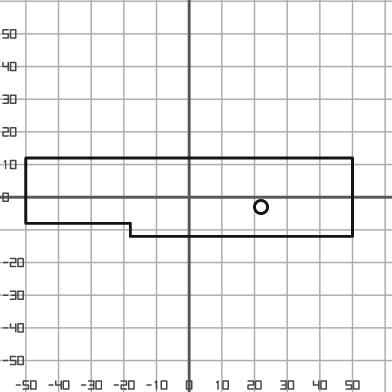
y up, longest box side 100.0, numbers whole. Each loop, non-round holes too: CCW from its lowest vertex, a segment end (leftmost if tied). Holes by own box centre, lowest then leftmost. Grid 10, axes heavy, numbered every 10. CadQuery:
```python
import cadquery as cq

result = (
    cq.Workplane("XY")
    .moveTo(-18.0, -12.0)
    .lineTo(50.0, -12.0)
    .lineTo(50.0, 12.0)
    .lineTo(-50.0, 12.0)
    .lineTo(-50.0, -8.0)
    .lineTo(-18.0, -8.0)
    .close()
    .moveTo(22.0, -3.0)
    .circle(2.0)
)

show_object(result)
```